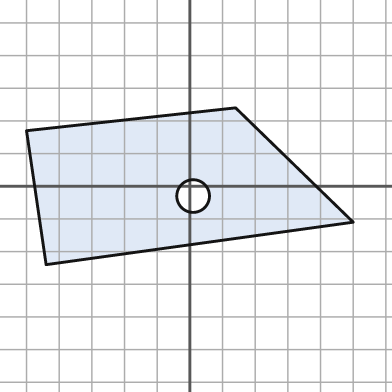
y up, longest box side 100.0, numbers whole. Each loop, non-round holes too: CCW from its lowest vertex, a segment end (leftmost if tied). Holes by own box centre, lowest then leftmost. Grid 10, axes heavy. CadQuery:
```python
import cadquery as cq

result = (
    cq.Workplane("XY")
    .moveTo(-44.0, -24.0)
    .lineTo(50.0, -11.0)
    .lineTo(14.0, 24.0)
    .lineTo(-50.0, 17.0)
    .close()
    .moveTo(1.0, -3.0)
    .circle(5.0)
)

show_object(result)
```